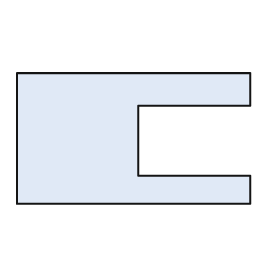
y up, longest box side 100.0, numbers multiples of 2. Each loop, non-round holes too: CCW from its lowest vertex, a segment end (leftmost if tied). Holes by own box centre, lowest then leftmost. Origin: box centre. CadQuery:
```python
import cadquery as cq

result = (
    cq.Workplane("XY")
    .moveTo(-50.0, -28.0)
    .lineTo(50.0, -28.0)
    .lineTo(50.0, -16.0)
    .lineTo(2.0, -16.0)
    .lineTo(2.0, 14.0)
    .lineTo(50.0, 14.0)
    .lineTo(50.0, 28.0)
    .lineTo(-50.0, 28.0)
    .close()
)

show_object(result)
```